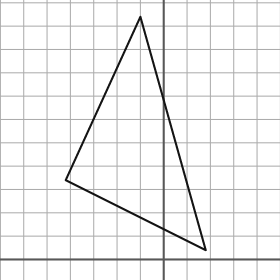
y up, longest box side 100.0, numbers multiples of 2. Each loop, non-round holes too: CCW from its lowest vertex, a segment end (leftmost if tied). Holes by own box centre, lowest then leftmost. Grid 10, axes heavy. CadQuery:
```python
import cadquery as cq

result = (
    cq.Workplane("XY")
    .moveTo(18.0, 4.0)
    .lineTo(-10.0, 104.0)
    .lineTo(-42.0, 34.0)
    .close()
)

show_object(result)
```